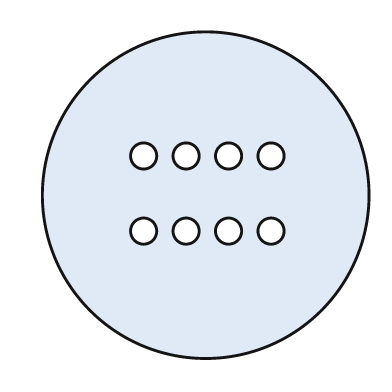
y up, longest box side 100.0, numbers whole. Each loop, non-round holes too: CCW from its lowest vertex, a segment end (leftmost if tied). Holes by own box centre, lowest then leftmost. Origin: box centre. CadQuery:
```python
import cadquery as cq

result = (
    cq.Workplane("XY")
    .moveTo(0.0, 0.0)
    .circle(50.0)
    .moveTo(-19.0, -11.0)
    .circle(4.0)
    .moveTo(-6.0, -11.0)
    .circle(4.0)
    .moveTo(7.0, -11.0)
    .circle(4.0)
    .moveTo(20.0, -11.0)
    .circle(4.0)
    .moveTo(-19.0, 12.0)
    .circle(4.0)
    .moveTo(-6.0, 12.0)
    .circle(4.0)
    .moveTo(7.0, 12.0)
    .circle(4.0)
    .moveTo(20.0, 12.0)
    .circle(4.0)
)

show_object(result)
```